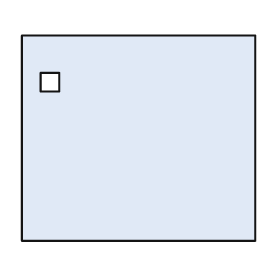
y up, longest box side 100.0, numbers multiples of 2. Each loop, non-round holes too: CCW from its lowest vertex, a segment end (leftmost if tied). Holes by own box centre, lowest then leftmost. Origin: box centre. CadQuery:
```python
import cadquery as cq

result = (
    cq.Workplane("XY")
    .moveTo(-50.0, -44.0)
    .lineTo(50.0, -44.0)
    .lineTo(50.0, 44.0)
    .lineTo(-50.0, 44.0)
    .close()
    .moveTo(-42.0, 20.0)
    .lineTo(-34.0, 20.0)
    .lineTo(-34.0, 28.0)
    .lineTo(-42.0, 28.0)
    .close()
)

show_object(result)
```